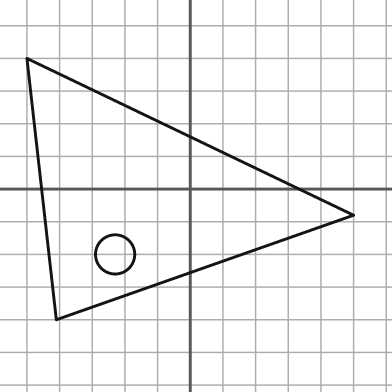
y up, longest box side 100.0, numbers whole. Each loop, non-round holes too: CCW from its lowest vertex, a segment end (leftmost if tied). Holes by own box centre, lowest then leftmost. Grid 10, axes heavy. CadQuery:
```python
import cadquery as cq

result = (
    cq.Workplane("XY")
    .moveTo(-41.0, -40.0)
    .lineTo(50.0, -8.0)
    .lineTo(-50.0, 40.0)
    .close()
    .moveTo(-23.0, -20.0)
    .circle(6.0)
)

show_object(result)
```